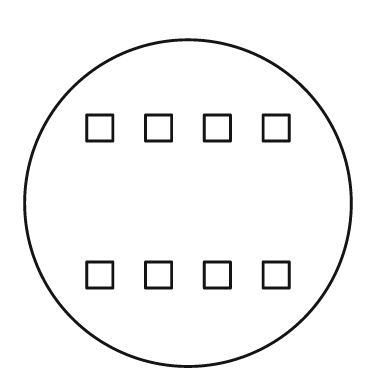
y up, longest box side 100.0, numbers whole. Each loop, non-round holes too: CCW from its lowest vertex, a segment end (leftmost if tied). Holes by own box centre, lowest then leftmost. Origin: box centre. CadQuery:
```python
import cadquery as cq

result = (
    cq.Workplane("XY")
    .moveTo(0.0, 0.0)
    .circle(50.0)
    .moveTo(-31.0, -26.0)
    .lineTo(-23.0, -26.0)
    .lineTo(-23.0, -18.0)
    .lineTo(-31.0, -18.0)
    .close()
    .moveTo(-13.0, -26.0)
    .lineTo(-5.0, -26.0)
    .lineTo(-5.0, -18.0)
    .lineTo(-13.0, -18.0)
    .close()
    .moveTo(5.0, -26.0)
    .lineTo(13.0, -26.0)
    .lineTo(13.0, -18.0)
    .lineTo(5.0, -18.0)
    .close()
    .moveTo(23.0, -26.0)
    .lineTo(31.0, -26.0)
    .lineTo(31.0, -18.0)
    .lineTo(23.0, -18.0)
    .close()
    .moveTo(-31.0, 19.0)
    .lineTo(-23.0, 19.0)
    .lineTo(-23.0, 27.0)
    .lineTo(-31.0, 27.0)
    .close()
    .moveTo(-13.0, 19.0)
    .lineTo(-5.0, 19.0)
    .lineTo(-5.0, 27.0)
    .lineTo(-13.0, 27.0)
    .close()
    .moveTo(5.0, 19.0)
    .lineTo(13.0, 19.0)
    .lineTo(13.0, 27.0)
    .lineTo(5.0, 27.0)
    .close()
    .moveTo(23.0, 19.0)
    .lineTo(31.0, 19.0)
    .lineTo(31.0, 27.0)
    .lineTo(23.0, 27.0)
    .close()
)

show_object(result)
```